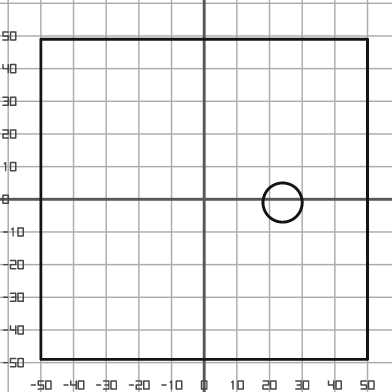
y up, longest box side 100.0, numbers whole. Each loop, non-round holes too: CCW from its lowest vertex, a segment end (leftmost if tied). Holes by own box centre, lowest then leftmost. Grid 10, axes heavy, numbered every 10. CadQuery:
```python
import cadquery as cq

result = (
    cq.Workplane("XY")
    .moveTo(-50.0, -49.0)
    .lineTo(50.0, -49.0)
    .lineTo(50.0, 49.0)
    .lineTo(-50.0, 49.0)
    .close()
    .moveTo(24.0, -1.0)
    .circle(6.0)
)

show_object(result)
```